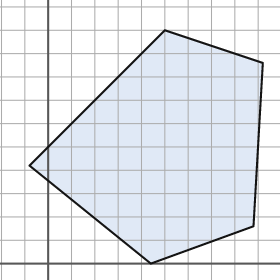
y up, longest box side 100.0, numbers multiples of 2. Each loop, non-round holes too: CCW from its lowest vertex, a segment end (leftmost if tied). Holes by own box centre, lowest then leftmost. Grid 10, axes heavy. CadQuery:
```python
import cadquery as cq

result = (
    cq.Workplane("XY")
    .moveTo(44.0, 0.0)
    .lineTo(88.0, 16.0)
    .lineTo(92.0, 86.0)
    .lineTo(50.0, 100.0)
    .lineTo(-8.0, 42.0)
    .close()
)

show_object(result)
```